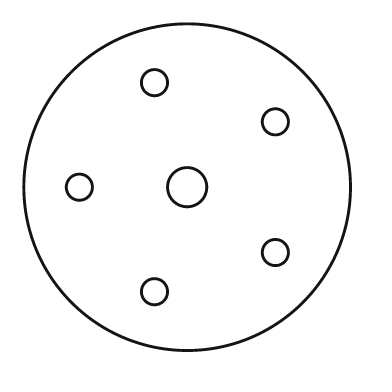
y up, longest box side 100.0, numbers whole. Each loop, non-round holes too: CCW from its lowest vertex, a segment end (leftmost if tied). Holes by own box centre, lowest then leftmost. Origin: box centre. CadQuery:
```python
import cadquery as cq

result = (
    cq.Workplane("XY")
    .moveTo(0.0, 0.0)
    .circle(50.0)
    .moveTo(-10.0, -32.0)
    .circle(4.0)
    .moveTo(27.0, -20.0)
    .circle(4.0)
    .moveTo(-33.0, 0.0)
    .circle(4.0)
    .moveTo(0.0, 0.0)
    .circle(6.0)
    .moveTo(27.0, 20.0)
    .circle(4.0)
    .moveTo(-10.0, 32.0)
    .circle(4.0)
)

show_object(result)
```